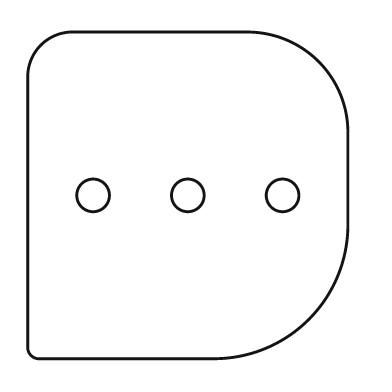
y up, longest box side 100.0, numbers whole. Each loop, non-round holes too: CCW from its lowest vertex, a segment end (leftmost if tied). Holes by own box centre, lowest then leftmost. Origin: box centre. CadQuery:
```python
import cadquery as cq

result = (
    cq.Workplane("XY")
    .moveTo(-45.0, -50.0)
    .lineTo(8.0, -50.0)
    .threePointArc((37.0, -38.0), (49.0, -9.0))
    .lineTo(49.0, 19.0)
    .threePointArc((40.0, 41.0), (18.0, 50.0))
    .lineTo(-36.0, 50.0)
    .threePointArc((-45.0, 46.0), (-49.0, 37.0))
    .lineTo(-49.0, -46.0)
    .threePointArc((-48.0, -49.0), (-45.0, -50.0))
    .close()
    .moveTo(-29.0, 0.0)
    .circle(5.0)
    .moveTo(0.0, 0.0)
    .circle(5.0)
    .moveTo(29.0, 0.0)
    .circle(5.0)
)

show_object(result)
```